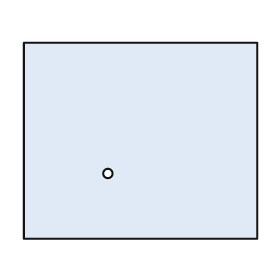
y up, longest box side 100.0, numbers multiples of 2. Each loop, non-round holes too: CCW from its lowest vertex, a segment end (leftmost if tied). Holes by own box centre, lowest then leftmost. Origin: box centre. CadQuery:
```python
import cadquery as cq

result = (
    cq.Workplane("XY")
    .moveTo(-50.0, -42.0)
    .lineTo(50.0, -42.0)
    .lineTo(50.0, 42.0)
    .lineTo(-50.0, 42.0)
    .close()
    .moveTo(-14.0, -14.0)
    .circle(2.0)
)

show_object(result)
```